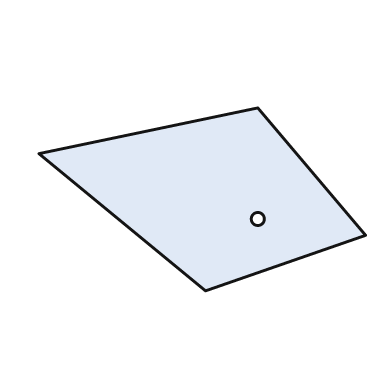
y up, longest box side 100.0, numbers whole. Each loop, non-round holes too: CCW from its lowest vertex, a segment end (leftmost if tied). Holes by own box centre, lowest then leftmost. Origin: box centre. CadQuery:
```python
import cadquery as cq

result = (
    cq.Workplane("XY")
    .moveTo(1.0, -28.0)
    .lineTo(50.0, -11.0)
    .lineTo(17.0, 28.0)
    .lineTo(-50.0, 14.0)
    .close()
    .moveTo(17.0, -6.0)
    .circle(2.0)
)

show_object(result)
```